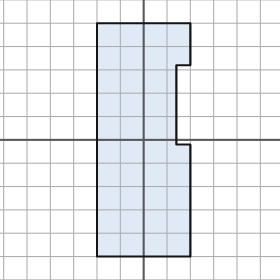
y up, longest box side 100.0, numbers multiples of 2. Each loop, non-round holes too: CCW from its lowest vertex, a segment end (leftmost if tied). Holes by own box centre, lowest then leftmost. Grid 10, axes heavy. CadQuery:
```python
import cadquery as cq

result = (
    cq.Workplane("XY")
    .moveTo(-20.0, -50.0)
    .lineTo(20.0, -50.0)
    .lineTo(20.0, -2.0)
    .lineTo(14.0, -2.0)
    .lineTo(14.0, 32.0)
    .lineTo(20.0, 32.0)
    .lineTo(20.0, 50.0)
    .lineTo(-20.0, 50.0)
    .close()
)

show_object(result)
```